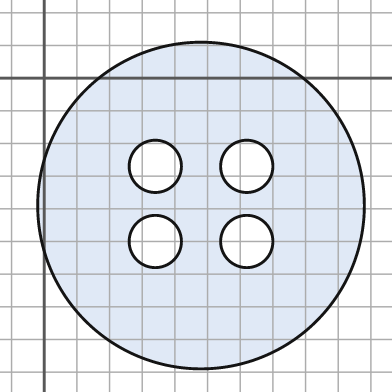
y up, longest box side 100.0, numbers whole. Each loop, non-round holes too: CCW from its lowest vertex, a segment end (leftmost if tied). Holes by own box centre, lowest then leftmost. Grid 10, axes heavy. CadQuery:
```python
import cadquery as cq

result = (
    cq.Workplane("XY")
    .moveTo(48.0, -39.0)
    .circle(50.0)
    .moveTo(34.0, -50.0)
    .circle(8.0)
    .moveTo(62.0, -50.0)
    .circle(8.0)
    .moveTo(34.0, -27.0)
    .circle(8.0)
    .moveTo(62.0, -27.0)
    .circle(8.0)
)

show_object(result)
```